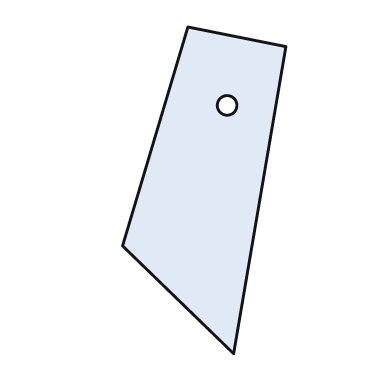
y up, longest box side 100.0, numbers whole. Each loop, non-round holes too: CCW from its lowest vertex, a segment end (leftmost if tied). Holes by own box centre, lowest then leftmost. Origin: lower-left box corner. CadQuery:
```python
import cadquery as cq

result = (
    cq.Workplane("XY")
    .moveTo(34.0, 0.0)
    .lineTo(50.0, 94.0)
    .lineTo(20.0, 100.0)
    .lineTo(0.0, 33.0)
    .close()
    .moveTo(32.0, 76.0)
    .circle(3.0)
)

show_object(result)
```